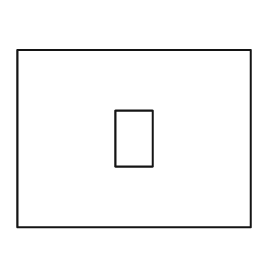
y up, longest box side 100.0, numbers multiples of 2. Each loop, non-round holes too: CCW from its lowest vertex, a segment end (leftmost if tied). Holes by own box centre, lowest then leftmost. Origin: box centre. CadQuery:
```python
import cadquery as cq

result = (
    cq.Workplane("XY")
    .moveTo(-50.0, -38.0)
    .lineTo(50.0, -38.0)
    .lineTo(50.0, 38.0)
    .lineTo(-50.0, 38.0)
    .close()
    .moveTo(-8.0, -12.0)
    .lineTo(8.0, -12.0)
    .lineTo(8.0, 12.0)
    .lineTo(-8.0, 12.0)
    .close()
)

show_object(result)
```